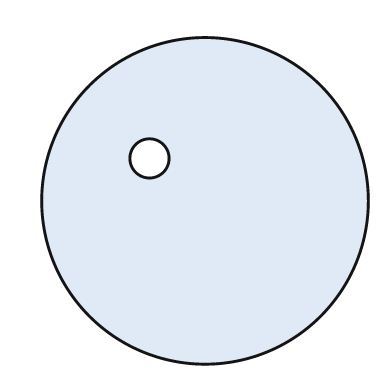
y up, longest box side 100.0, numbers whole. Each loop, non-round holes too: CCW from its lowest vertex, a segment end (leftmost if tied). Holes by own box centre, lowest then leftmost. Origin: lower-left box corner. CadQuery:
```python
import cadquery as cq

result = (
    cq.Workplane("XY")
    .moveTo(50.0, 50.0)
    .circle(50.0)
    .moveTo(33.0, 63.0)
    .circle(6.0)
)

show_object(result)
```